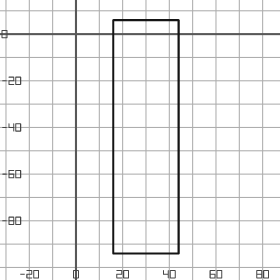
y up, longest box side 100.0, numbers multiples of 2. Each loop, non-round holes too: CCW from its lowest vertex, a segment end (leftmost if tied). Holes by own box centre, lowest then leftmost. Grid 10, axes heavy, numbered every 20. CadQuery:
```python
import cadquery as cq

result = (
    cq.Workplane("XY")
    .moveTo(16.0, -94.0)
    .lineTo(44.0, -94.0)
    .lineTo(44.0, 6.0)
    .lineTo(16.0, 6.0)
    .close()
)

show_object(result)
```